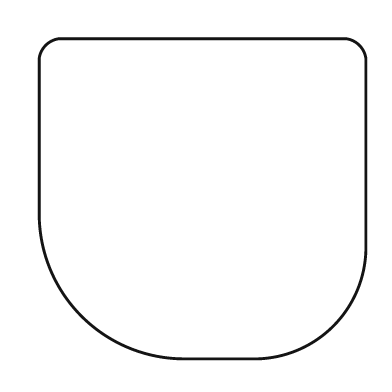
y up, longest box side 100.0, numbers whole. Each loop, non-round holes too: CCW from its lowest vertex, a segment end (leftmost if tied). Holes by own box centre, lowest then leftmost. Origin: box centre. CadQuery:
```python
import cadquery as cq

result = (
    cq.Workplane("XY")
    .moveTo(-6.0, -49.0)
    .lineTo(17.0, -49.0)
    .threePointArc((40.0, -39.0), (50.0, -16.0))
    .lineTo(50.0, 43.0)
    .threePointArc((48.0, 47.0), (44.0, 49.0))
    .lineTo(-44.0, 49.0)
    .threePointArc((-48.0, 47.0), (-50.0, 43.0))
    .lineTo(-50.0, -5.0)
    .threePointArc((-37.0, -36.0), (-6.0, -49.0))
    .close()
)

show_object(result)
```